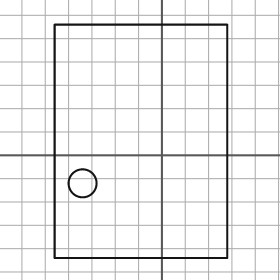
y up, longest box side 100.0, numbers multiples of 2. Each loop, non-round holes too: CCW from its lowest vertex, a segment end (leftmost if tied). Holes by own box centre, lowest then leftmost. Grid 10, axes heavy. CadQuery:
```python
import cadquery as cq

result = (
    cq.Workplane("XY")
    .moveTo(-46.0, -44.0)
    .lineTo(28.0, -44.0)
    .lineTo(28.0, 56.0)
    .lineTo(-46.0, 56.0)
    .close()
    .moveTo(-34.0, -12.0)
    .circle(6.0)
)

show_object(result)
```